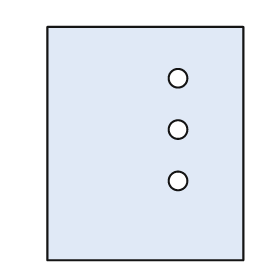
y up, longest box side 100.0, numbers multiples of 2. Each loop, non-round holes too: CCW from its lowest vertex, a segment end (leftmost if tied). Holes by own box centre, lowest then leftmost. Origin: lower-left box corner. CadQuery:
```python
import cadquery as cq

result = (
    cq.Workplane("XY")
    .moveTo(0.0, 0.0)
    .lineTo(84.0, 0.0)
    .lineTo(84.0, 100.0)
    .lineTo(0.0, 100.0)
    .close()
    .moveTo(56.0, 34.0)
    .circle(4.0)
    .moveTo(56.0, 56.0)
    .circle(4.0)
    .moveTo(56.0, 78.0)
    .circle(4.0)
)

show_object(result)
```